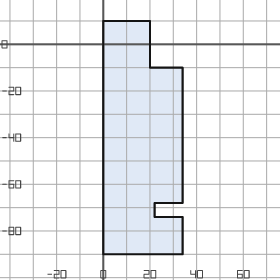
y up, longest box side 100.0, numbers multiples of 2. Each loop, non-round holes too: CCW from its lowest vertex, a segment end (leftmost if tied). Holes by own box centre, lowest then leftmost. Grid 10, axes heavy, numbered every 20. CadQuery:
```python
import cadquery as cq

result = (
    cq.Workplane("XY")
    .moveTo(0.0, -90.0)
    .lineTo(34.0, -90.0)
    .lineTo(34.0, -74.0)
    .lineTo(22.0, -74.0)
    .lineTo(22.0, -68.0)
    .lineTo(34.0, -68.0)
    .lineTo(34.0, -10.0)
    .lineTo(20.0, -10.0)
    .lineTo(20.0, 10.0)
    .lineTo(0.0, 10.0)
    .close()
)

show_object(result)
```